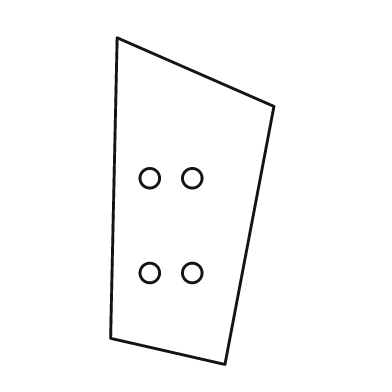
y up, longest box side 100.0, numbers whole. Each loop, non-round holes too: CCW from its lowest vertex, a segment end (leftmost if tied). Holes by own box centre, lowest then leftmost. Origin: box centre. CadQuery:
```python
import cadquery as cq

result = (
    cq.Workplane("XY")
    .moveTo(10.0, -50.0)
    .lineTo(25.0, 29.0)
    .lineTo(-23.0, 50.0)
    .lineTo(-25.0, -42.0)
    .close()
    .moveTo(-13.0, -22.0)
    .circle(3.0)
    .moveTo(0.0, -22.0)
    .circle(3.0)
    .moveTo(-13.0, 7.0)
    .circle(3.0)
    .moveTo(0.0, 7.0)
    .circle(3.0)
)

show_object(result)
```